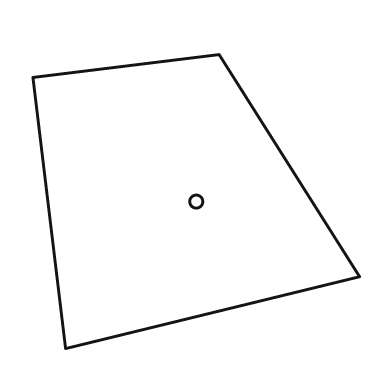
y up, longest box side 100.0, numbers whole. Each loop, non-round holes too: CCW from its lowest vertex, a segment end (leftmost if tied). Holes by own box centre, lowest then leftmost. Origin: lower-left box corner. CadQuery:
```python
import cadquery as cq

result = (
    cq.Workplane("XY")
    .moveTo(10.0, 0.0)
    .lineTo(100.0, 22.0)
    .lineTo(57.0, 90.0)
    .lineTo(0.0, 83.0)
    .close()
    .moveTo(50.0, 45.0)
    .circle(2.0)
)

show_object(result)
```